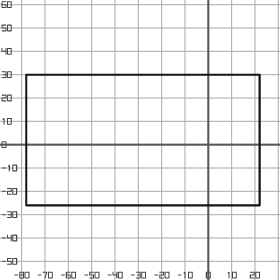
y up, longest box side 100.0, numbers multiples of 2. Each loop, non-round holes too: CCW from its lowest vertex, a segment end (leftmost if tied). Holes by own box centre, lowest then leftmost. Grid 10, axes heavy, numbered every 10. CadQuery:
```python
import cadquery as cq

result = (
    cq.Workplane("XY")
    .moveTo(-78.0, -26.0)
    .lineTo(22.0, -26.0)
    .lineTo(22.0, 30.0)
    .lineTo(-78.0, 30.0)
    .close()
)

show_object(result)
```